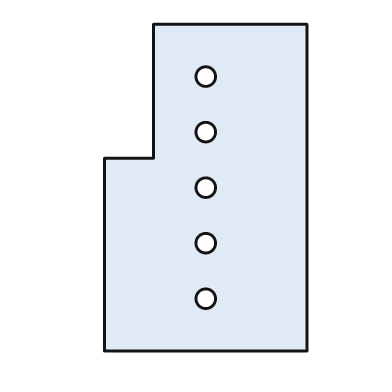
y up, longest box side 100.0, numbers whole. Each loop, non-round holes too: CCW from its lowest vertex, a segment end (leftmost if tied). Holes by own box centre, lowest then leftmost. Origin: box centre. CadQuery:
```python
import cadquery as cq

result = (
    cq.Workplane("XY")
    .moveTo(-31.0, -50.0)
    .lineTo(31.0, -50.0)
    .lineTo(31.0, 50.0)
    .lineTo(-16.0, 50.0)
    .lineTo(-16.0, 9.0)
    .lineTo(-31.0, 9.0)
    .close()
    .moveTo(0.0, -34.0)
    .circle(3.0)
    .moveTo(0.0, -17.0)
    .circle(3.0)
    .moveTo(0.0, 0.0)
    .circle(3.0)
    .moveTo(0.0, 17.0)
    .circle(3.0)
    .moveTo(0.0, 34.0)
    .circle(3.0)
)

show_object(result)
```